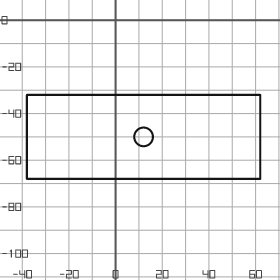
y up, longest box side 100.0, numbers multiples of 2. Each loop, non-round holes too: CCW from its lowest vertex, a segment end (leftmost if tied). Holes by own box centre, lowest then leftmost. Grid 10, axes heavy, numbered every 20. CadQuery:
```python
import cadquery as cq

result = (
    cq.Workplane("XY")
    .moveTo(-38.0, -68.0)
    .lineTo(62.0, -68.0)
    .lineTo(62.0, -32.0)
    .lineTo(-38.0, -32.0)
    .close()
    .moveTo(12.0, -50.0)
    .circle(4.0)
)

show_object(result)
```